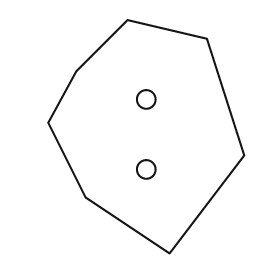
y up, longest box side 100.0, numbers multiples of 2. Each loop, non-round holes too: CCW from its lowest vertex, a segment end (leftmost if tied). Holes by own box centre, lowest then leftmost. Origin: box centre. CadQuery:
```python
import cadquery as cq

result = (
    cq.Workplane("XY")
    .moveTo(10.0, -50.0)
    .lineTo(42.0, -8.0)
    .lineTo(26.0, 42.0)
    .lineTo(-8.0, 50.0)
    .lineTo(-30.0, 28.0)
    .lineTo(-42.0, 6.0)
    .lineTo(-26.0, -26.0)
    .close()
    .moveTo(0.0, -14.0)
    .circle(4.0)
    .moveTo(0.0, 16.0)
    .circle(4.0)
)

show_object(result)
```